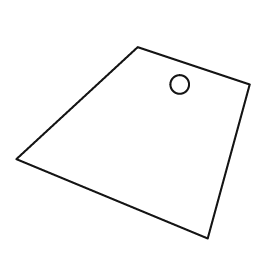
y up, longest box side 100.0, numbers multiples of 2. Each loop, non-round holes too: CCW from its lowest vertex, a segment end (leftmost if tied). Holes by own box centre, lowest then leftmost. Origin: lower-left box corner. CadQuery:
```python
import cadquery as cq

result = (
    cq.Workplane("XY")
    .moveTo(82.0, 0.0)
    .lineTo(100.0, 66.0)
    .lineTo(52.0, 82.0)
    .lineTo(0.0, 34.0)
    .close()
    .moveTo(70.0, 66.0)
    .circle(4.0)
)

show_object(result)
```